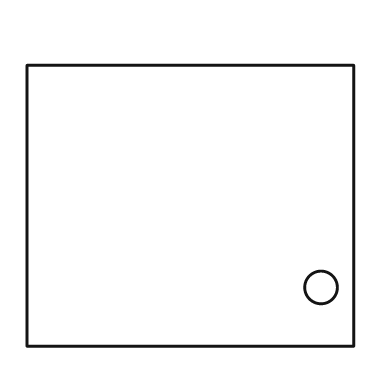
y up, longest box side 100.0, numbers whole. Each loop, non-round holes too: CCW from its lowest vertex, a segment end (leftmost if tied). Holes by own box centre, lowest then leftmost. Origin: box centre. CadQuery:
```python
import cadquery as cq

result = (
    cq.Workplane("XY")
    .moveTo(-50.0, -43.0)
    .lineTo(50.0, -43.0)
    .lineTo(50.0, 43.0)
    .lineTo(-50.0, 43.0)
    .close()
    .moveTo(40.0, -25.0)
    .circle(5.0)
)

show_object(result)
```